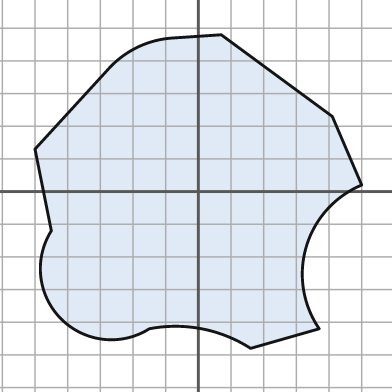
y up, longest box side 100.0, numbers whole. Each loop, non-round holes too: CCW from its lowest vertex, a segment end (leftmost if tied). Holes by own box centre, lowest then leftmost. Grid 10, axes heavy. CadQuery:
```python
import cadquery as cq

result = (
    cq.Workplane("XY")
    .moveTo(16.0, -48.0)
    .lineTo(37.0, -42.0)
    .threePointArc((33.0, -17.0), (50.0, 2.0))
    .lineTo(41.0, 23.0)
    .lineTo(7.0, 48.0)
    .lineTo(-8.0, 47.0)
    .threePointArc((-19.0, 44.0), (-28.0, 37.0))
    .lineTo(-50.0, 13.0)
    .lineTo(-45.0, -12.0)
    .threePointArc((-42.0, -39.0), (-15.0, -42.0))
    .threePointArc((1.0, -42.0), (16.0, -48.0))
    .close()
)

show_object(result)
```